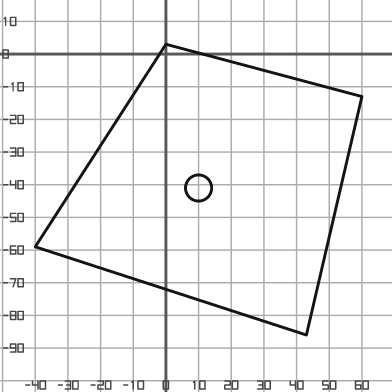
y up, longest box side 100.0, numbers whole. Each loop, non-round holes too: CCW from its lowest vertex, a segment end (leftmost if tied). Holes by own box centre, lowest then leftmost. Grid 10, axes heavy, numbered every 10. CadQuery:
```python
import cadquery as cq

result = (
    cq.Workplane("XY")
    .moveTo(43.0, -86.0)
    .lineTo(60.0, -13.0)
    .lineTo(0.0, 3.0)
    .lineTo(-40.0, -59.0)
    .close()
    .moveTo(10.0, -41.0)
    .circle(4.0)
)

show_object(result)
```